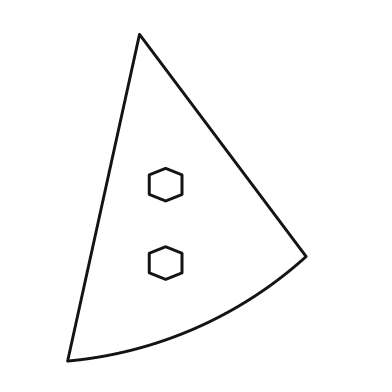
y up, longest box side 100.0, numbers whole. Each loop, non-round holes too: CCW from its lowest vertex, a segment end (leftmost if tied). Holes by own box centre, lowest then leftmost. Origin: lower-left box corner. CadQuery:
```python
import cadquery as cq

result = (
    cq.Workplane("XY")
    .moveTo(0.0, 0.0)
    .threePointArc((39.0, 10.0), (73.0, 32.0))
    .lineTo(22.0, 100.0)
    .close()
    .moveTo(30.0, 25.0)
    .lineTo(35.0, 27.0)
    .lineTo(35.0, 33.0)
    .lineTo(30.0, 35.0)
    .lineTo(25.0, 33.0)
    .lineTo(25.0, 27.0)
    .close()
    .moveTo(30.0, 49.0)
    .lineTo(35.0, 51.0)
    .lineTo(35.0, 57.0)
    .lineTo(30.0, 59.0)
    .lineTo(25.0, 57.0)
    .lineTo(25.0, 51.0)
    .close()
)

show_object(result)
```